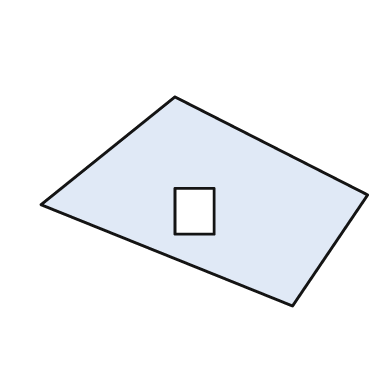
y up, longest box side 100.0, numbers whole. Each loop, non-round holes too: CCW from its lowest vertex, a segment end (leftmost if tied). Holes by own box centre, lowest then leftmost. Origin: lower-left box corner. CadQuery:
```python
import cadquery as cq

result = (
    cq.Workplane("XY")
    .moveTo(77.0, 0.0)
    .lineTo(100.0, 34.0)
    .lineTo(41.0, 64.0)
    .lineTo(0.0, 31.0)
    .close()
    .moveTo(41.0, 22.0)
    .lineTo(53.0, 22.0)
    .lineTo(53.0, 36.0)
    .lineTo(41.0, 36.0)
    .close()
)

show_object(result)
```